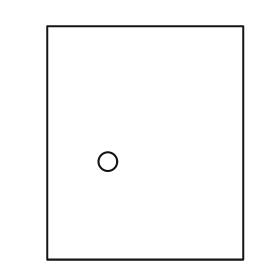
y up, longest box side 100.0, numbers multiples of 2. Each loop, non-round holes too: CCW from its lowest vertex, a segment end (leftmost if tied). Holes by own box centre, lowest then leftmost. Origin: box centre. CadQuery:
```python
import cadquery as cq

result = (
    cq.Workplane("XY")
    .moveTo(-42.0, -50.0)
    .lineTo(42.0, -50.0)
    .lineTo(42.0, 50.0)
    .lineTo(-42.0, 50.0)
    .close()
    .moveTo(-16.0, -8.0)
    .circle(4.0)
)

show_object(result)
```